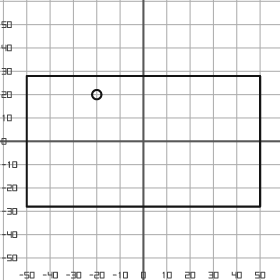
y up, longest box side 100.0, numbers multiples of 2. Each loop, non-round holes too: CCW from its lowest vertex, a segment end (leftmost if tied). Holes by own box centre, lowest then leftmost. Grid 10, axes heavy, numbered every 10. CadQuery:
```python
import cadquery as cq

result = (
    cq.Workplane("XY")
    .moveTo(-50.0, -28.0)
    .lineTo(50.0, -28.0)
    .lineTo(50.0, 28.0)
    .lineTo(-50.0, 28.0)
    .close()
    .moveTo(-20.0, 20.0)
    .circle(2.0)
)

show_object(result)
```